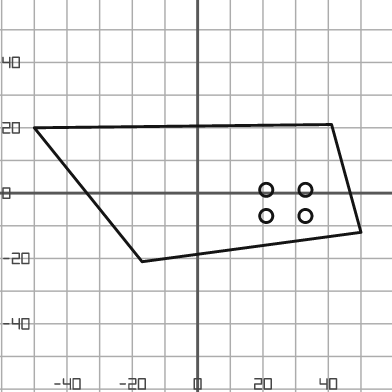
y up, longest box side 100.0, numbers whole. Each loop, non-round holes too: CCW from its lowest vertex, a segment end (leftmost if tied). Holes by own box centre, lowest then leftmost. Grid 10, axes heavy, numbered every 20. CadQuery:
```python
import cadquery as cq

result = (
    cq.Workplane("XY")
    .moveTo(-17.0, -21.0)
    .lineTo(50.0, -12.0)
    .lineTo(41.0, 21.0)
    .lineTo(-50.0, 20.0)
    .close()
    .moveTo(21.0, -7.0)
    .circle(2.0)
    .moveTo(33.0, -7.0)
    .circle(2.0)
    .moveTo(21.0, 1.0)
    .circle(2.0)
    .moveTo(33.0, 1.0)
    .circle(2.0)
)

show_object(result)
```